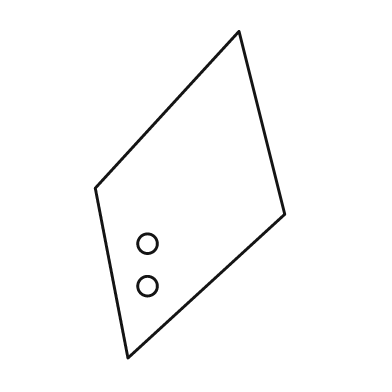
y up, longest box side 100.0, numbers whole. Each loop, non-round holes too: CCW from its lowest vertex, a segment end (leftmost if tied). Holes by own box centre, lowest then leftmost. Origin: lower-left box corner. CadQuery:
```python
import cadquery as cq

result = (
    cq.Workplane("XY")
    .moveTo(10.0, 0.0)
    .lineTo(58.0, 44.0)
    .lineTo(44.0, 100.0)
    .lineTo(0.0, 52.0)
    .close()
    .moveTo(16.0, 22.0)
    .circle(3.0)
    .moveTo(16.0, 35.0)
    .circle(3.0)
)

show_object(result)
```